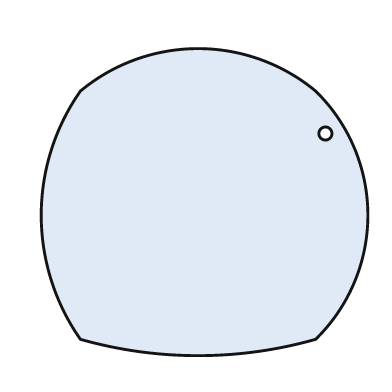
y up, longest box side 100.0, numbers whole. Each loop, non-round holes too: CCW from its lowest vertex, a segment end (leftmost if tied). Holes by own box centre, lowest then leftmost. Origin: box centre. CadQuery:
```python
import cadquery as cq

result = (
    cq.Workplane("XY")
    .moveTo(-38.0, -42.0)
    .threePointArc((-2.0, -47.0), (34.0, -42.0))
    .threePointArc((50.0, -4.0), (34.0, 34.0))
    .threePointArc((-2.0, 47.0), (-38.0, 34.0))
    .threePointArc((-50.0, -4.0), (-38.0, -42.0))
    .close()
    .moveTo(37.0, 21.0)
    .circle(2.0)
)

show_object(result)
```